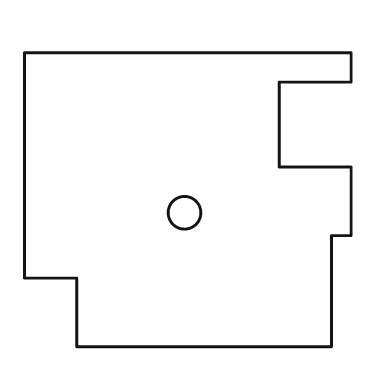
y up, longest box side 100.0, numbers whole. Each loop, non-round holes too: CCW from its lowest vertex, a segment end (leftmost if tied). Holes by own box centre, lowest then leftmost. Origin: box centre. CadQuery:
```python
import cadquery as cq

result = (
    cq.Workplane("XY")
    .moveTo(-34.0, -45.0)
    .lineTo(44.0, -45.0)
    .lineTo(44.0, -11.0)
    .lineTo(50.0, -11.0)
    .lineTo(50.0, 10.0)
    .lineTo(28.0, 10.0)
    .lineTo(28.0, 36.0)
    .lineTo(50.0, 36.0)
    .lineTo(50.0, 45.0)
    .lineTo(-50.0, 45.0)
    .lineTo(-50.0, -24.0)
    .lineTo(-34.0, -24.0)
    .close()
    .moveTo(-1.0, -4.0)
    .circle(5.0)
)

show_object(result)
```